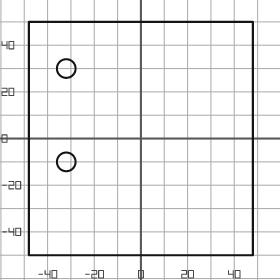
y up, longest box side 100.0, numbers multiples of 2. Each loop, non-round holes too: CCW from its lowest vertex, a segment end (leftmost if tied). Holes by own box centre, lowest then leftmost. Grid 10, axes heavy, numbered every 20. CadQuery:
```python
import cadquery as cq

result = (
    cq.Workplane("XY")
    .moveTo(-48.0, -50.0)
    .lineTo(48.0, -50.0)
    .lineTo(48.0, 50.0)
    .lineTo(-48.0, 50.0)
    .close()
    .moveTo(-32.0, -10.0)
    .circle(4.0)
    .moveTo(-32.0, 30.0)
    .circle(4.0)
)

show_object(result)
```